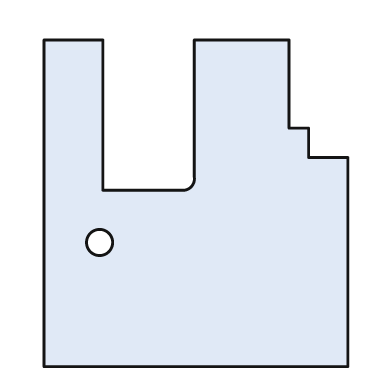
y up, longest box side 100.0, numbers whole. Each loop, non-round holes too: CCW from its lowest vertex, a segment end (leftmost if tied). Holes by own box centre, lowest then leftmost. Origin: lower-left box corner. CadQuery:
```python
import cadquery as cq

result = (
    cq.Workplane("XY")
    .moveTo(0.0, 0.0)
    .lineTo(93.0, 0.0)
    .lineTo(93.0, 64.0)
    .lineTo(81.0, 64.0)
    .lineTo(81.0, 73.0)
    .lineTo(75.0, 73.0)
    .lineTo(75.0, 100.0)
    .lineTo(46.0, 100.0)
    .lineTo(46.0, 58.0)
    .threePointArc((45.0, 55.0), (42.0, 54.0))
    .lineTo(18.0, 54.0)
    .lineTo(18.0, 100.0)
    .lineTo(0.0, 100.0)
    .close()
    .moveTo(17.0, 38.0)
    .circle(4.0)
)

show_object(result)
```